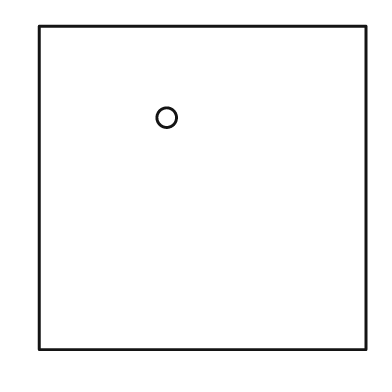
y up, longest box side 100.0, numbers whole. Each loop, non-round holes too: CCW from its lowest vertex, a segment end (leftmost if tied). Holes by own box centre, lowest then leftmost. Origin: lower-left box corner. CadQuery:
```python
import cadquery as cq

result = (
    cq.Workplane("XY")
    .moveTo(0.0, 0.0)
    .lineTo(100.0, 0.0)
    .lineTo(100.0, 99.0)
    .lineTo(0.0, 99.0)
    .close()
    .moveTo(39.0, 71.0)
    .circle(3.0)
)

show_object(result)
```